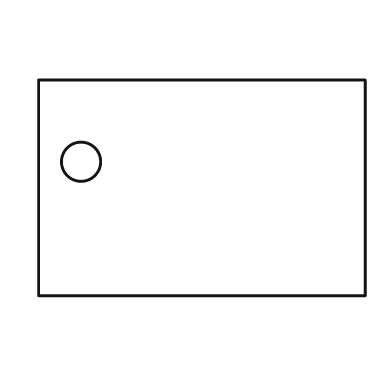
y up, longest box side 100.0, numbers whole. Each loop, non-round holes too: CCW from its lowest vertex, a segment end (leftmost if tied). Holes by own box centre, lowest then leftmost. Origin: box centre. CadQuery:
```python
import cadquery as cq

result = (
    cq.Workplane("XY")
    .moveTo(-50.0, -33.0)
    .lineTo(50.0, -33.0)
    .lineTo(50.0, 33.0)
    .lineTo(-50.0, 33.0)
    .close()
    .moveTo(-37.0, 8.0)
    .circle(6.0)
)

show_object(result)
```